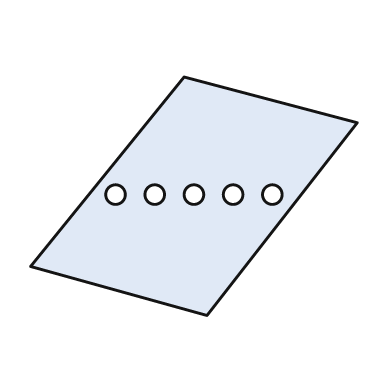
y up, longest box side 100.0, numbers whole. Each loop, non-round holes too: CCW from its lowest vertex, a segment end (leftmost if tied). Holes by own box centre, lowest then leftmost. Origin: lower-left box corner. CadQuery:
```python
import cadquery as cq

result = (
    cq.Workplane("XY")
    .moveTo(54.0, 0.0)
    .lineTo(100.0, 59.0)
    .lineTo(47.0, 73.0)
    .lineTo(0.0, 15.0)
    .close()
    .moveTo(26.0, 37.0)
    .circle(3.0)
    .moveTo(38.0, 37.0)
    .circle(3.0)
    .moveTo(50.0, 37.0)
    .circle(3.0)
    .moveTo(62.0, 37.0)
    .circle(3.0)
    .moveTo(74.0, 37.0)
    .circle(3.0)
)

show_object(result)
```